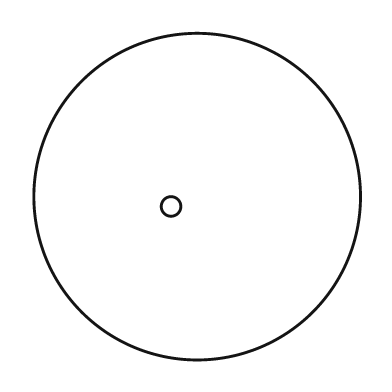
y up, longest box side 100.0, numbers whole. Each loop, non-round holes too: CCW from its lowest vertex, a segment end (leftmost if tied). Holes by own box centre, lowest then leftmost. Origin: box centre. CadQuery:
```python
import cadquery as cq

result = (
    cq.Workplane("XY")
    .moveTo(0.0, 0.0)
    .circle(50.0)
    .moveTo(-8.0, -3.0)
    .circle(3.0)
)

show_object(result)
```